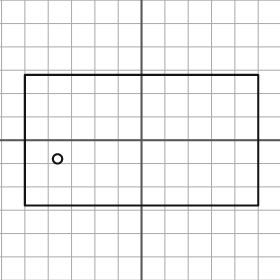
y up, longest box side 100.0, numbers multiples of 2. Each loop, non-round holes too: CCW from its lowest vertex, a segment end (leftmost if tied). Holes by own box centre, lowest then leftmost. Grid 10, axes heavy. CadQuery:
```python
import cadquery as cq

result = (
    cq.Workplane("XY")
    .moveTo(-50.0, -28.0)
    .lineTo(50.0, -28.0)
    .lineTo(50.0, 28.0)
    .lineTo(-50.0, 28.0)
    .close()
    .moveTo(-36.0, -8.0)
    .circle(2.0)
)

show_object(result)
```